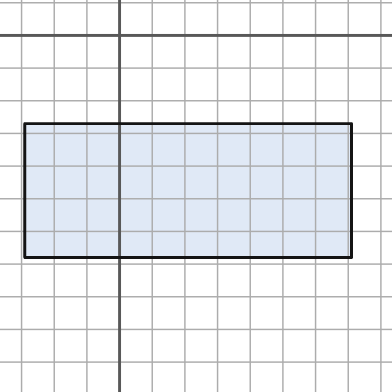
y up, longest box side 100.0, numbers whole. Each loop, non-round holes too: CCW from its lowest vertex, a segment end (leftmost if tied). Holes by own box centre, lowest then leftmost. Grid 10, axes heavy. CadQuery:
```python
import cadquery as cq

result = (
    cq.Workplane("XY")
    .moveTo(-29.0, -68.0)
    .lineTo(71.0, -68.0)
    .lineTo(71.0, -27.0)
    .lineTo(-29.0, -27.0)
    .close()
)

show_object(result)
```